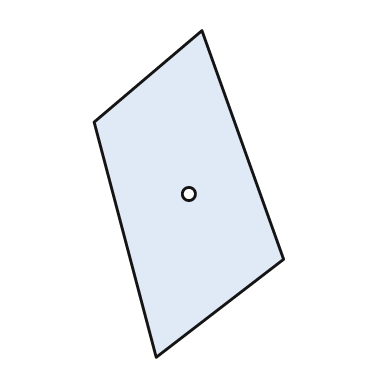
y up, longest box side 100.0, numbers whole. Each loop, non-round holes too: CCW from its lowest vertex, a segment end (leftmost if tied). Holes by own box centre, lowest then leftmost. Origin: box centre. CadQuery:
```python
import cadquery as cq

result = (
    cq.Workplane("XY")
    .moveTo(-10.0, -50.0)
    .lineTo(29.0, -20.0)
    .lineTo(4.0, 50.0)
    .lineTo(-29.0, 22.0)
    .close()
    .moveTo(0.0, 0.0)
    .circle(2.0)
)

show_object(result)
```